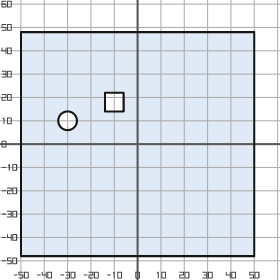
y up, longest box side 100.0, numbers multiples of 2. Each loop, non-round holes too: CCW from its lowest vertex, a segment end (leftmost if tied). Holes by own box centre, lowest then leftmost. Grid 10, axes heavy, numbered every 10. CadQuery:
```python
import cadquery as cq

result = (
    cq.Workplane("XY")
    .moveTo(-50.0, -48.0)
    .lineTo(50.0, -48.0)
    .lineTo(50.0, 48.0)
    .lineTo(-50.0, 48.0)
    .close()
    .moveTo(-30.0, 10.0)
    .circle(4.0)
    .moveTo(-14.0, 14.0)
    .lineTo(-6.0, 14.0)
    .lineTo(-6.0, 22.0)
    .lineTo(-14.0, 22.0)
    .close()
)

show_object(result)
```